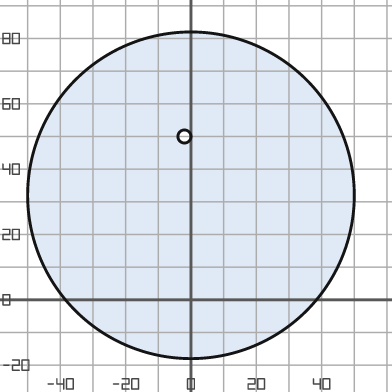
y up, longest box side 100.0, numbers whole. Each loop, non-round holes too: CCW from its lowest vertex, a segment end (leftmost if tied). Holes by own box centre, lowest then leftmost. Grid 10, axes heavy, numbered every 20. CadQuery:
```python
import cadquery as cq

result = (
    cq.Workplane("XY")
    .moveTo(0.0, 32.0)
    .circle(50.0)
    .moveTo(-2.0, 50.0)
    .circle(2.0)
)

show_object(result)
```